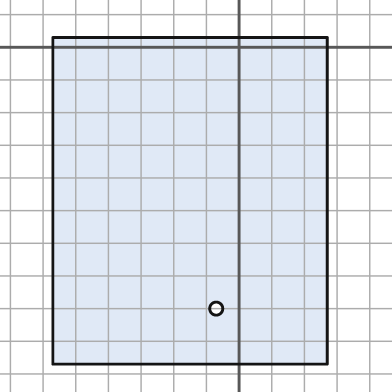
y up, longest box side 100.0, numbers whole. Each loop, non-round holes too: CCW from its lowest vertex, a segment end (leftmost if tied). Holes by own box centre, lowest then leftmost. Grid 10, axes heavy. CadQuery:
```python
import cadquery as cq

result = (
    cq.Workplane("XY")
    .moveTo(-57.0, -97.0)
    .lineTo(27.0, -97.0)
    .lineTo(27.0, 3.0)
    .lineTo(-57.0, 3.0)
    .close()
    .moveTo(-7.0, -80.0)
    .circle(2.0)
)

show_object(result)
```